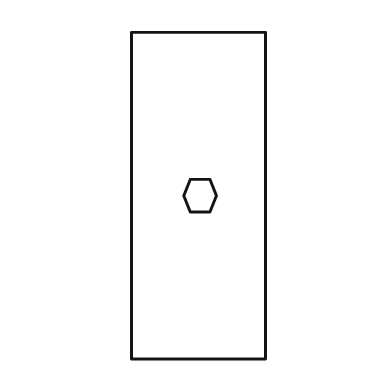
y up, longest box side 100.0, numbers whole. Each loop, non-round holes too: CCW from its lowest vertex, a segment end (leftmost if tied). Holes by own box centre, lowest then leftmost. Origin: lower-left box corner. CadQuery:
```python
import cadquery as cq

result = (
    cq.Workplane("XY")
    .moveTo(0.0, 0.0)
    .lineTo(41.0, 0.0)
    .lineTo(41.0, 100.0)
    .lineTo(0.0, 100.0)
    .close()
    .moveTo(18.0, 45.0)
    .lineTo(24.0, 45.0)
    .lineTo(26.0, 50.0)
    .lineTo(24.0, 55.0)
    .lineTo(18.0, 55.0)
    .lineTo(16.0, 50.0)
    .close()
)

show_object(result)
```